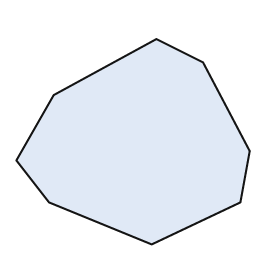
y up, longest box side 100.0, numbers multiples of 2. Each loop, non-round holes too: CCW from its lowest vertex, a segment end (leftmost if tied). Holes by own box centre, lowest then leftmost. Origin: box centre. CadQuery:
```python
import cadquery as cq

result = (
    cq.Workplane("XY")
    .moveTo(8.0, -44.0)
    .lineTo(46.0, -26.0)
    .lineTo(50.0, -4.0)
    .lineTo(30.0, 34.0)
    .lineTo(10.0, 44.0)
    .lineTo(-34.0, 20.0)
    .lineTo(-50.0, -8.0)
    .lineTo(-36.0, -26.0)
    .close()
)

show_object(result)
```